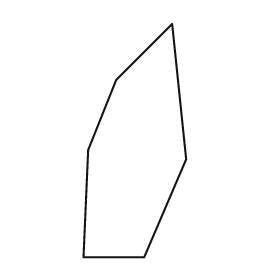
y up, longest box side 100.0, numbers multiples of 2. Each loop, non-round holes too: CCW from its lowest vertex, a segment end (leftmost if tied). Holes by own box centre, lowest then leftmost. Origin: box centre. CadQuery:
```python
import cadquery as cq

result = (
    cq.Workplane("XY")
    .moveTo(-22.0, -50.0)
    .lineTo(4.0, -50.0)
    .lineTo(22.0, -8.0)
    .lineTo(16.0, 50.0)
    .lineTo(-8.0, 26.0)
    .lineTo(-20.0, -4.0)
    .close()
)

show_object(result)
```